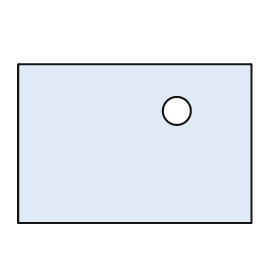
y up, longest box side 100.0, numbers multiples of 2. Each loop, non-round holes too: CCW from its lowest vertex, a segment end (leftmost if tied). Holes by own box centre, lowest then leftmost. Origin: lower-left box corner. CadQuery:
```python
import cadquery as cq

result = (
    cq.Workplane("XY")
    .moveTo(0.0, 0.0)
    .lineTo(100.0, 0.0)
    .lineTo(100.0, 68.0)
    .lineTo(0.0, 68.0)
    .close()
    .moveTo(68.0, 48.0)
    .circle(6.0)
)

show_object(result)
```